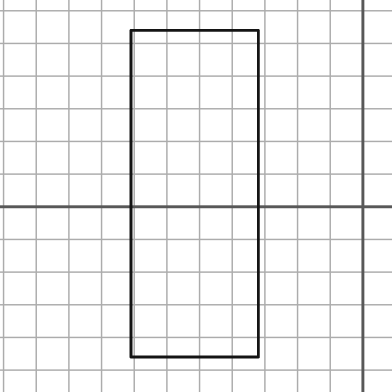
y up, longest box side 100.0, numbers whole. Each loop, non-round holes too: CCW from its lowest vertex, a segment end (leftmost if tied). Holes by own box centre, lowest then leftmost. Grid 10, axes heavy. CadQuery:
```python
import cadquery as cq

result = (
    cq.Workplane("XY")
    .moveTo(-71.0, -46.0)
    .lineTo(-32.0, -46.0)
    .lineTo(-32.0, 54.0)
    .lineTo(-71.0, 54.0)
    .close()
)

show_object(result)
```